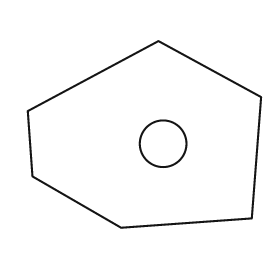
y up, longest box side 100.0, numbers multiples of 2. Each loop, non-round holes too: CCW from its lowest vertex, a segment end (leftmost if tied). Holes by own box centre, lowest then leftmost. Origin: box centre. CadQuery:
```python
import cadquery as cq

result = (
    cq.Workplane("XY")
    .moveTo(-10.0, -40.0)
    .lineTo(46.0, -36.0)
    .lineTo(50.0, 16.0)
    .lineTo(6.0, 40.0)
    .lineTo(-50.0, 10.0)
    .lineTo(-48.0, -18.0)
    .close()
    .moveTo(8.0, -4.0)
    .circle(10.0)
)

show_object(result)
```